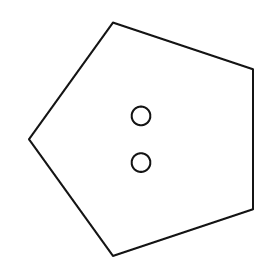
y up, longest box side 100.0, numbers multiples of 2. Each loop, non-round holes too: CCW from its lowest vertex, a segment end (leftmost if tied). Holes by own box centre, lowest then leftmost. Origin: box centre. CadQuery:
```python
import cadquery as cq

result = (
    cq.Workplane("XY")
    .moveTo(-12.0, -50.0)
    .lineTo(48.0, -30.0)
    .lineTo(48.0, 30.0)
    .lineTo(-12.0, 50.0)
    .lineTo(-48.0, 0.0)
    .close()
    .moveTo(0.0, -10.0)
    .circle(4.0)
    .moveTo(0.0, 10.0)
    .circle(4.0)
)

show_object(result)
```